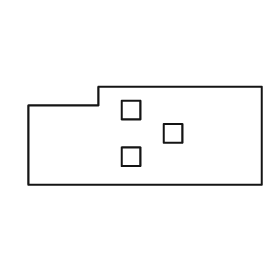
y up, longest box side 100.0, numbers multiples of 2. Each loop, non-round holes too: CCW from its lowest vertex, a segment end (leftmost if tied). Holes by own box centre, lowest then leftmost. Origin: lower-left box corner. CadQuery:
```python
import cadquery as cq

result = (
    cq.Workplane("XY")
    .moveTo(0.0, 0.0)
    .lineTo(100.0, 0.0)
    .lineTo(100.0, 42.0)
    .lineTo(30.0, 42.0)
    .lineTo(30.0, 34.0)
    .lineTo(0.0, 34.0)
    .close()
    .moveTo(40.0, 8.0)
    .lineTo(48.0, 8.0)
    .lineTo(48.0, 16.0)
    .lineTo(40.0, 16.0)
    .close()
    .moveTo(58.0, 18.0)
    .lineTo(66.0, 18.0)
    .lineTo(66.0, 26.0)
    .lineTo(58.0, 26.0)
    .close()
    .moveTo(40.0, 28.0)
    .lineTo(48.0, 28.0)
    .lineTo(48.0, 36.0)
    .lineTo(40.0, 36.0)
    .close()
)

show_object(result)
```